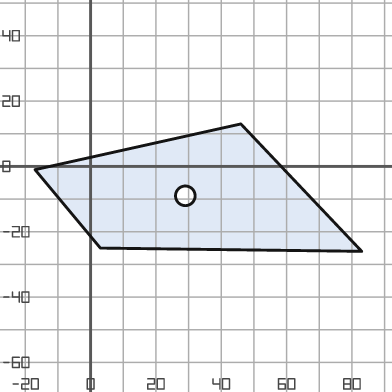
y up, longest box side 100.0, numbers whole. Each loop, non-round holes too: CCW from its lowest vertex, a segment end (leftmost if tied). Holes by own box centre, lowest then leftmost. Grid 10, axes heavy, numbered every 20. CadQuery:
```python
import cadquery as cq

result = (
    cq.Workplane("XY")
    .moveTo(83.0, -26.0)
    .lineTo(46.0, 13.0)
    .lineTo(-17.0, -1.0)
    .lineTo(3.0, -25.0)
    .close()
    .moveTo(29.0, -9.0)
    .circle(3.0)
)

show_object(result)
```